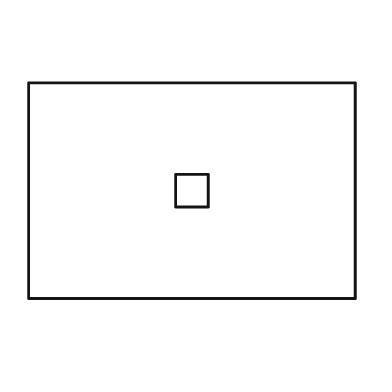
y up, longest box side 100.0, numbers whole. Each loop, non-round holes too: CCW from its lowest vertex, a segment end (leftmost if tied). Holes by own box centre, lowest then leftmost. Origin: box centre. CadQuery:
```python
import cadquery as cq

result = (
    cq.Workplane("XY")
    .moveTo(-50.0, -33.0)
    .lineTo(50.0, -33.0)
    .lineTo(50.0, 33.0)
    .lineTo(-50.0, 33.0)
    .close()
    .moveTo(-5.0, -5.0)
    .lineTo(5.0, -5.0)
    .lineTo(5.0, 5.0)
    .lineTo(-5.0, 5.0)
    .close()
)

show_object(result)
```